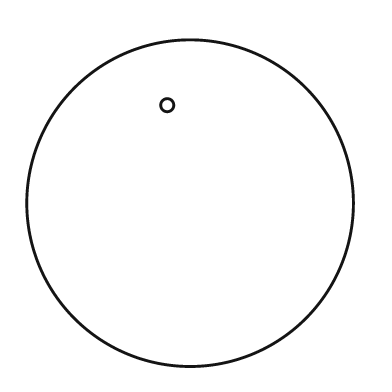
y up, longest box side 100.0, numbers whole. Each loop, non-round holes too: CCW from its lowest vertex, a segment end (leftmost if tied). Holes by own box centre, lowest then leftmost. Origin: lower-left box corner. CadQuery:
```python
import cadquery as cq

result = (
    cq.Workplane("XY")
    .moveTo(50.0, 50.0)
    .circle(50.0)
    .moveTo(43.0, 80.0)
    .circle(2.0)
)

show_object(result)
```